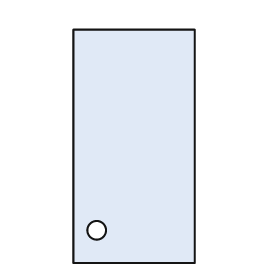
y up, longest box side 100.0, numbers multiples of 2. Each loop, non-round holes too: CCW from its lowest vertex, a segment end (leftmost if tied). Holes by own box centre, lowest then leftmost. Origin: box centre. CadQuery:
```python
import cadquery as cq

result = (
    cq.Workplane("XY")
    .moveTo(-26.0, -50.0)
    .lineTo(26.0, -50.0)
    .lineTo(26.0, 50.0)
    .lineTo(-26.0, 50.0)
    .close()
    .moveTo(-16.0, -36.0)
    .circle(4.0)
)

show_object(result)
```